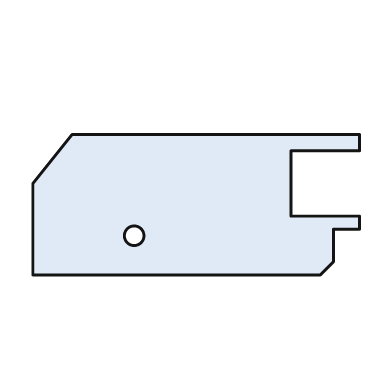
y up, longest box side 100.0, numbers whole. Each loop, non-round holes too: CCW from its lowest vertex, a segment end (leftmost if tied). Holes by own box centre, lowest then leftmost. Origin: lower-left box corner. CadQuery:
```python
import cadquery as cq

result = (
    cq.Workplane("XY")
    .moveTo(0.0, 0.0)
    .lineTo(88.0, 0.0)
    .lineTo(92.0, 4.0)
    .lineTo(92.0, 14.0)
    .lineTo(100.0, 14.0)
    .lineTo(100.0, 18.0)
    .lineTo(79.0, 18.0)
    .lineTo(79.0, 38.0)
    .lineTo(100.0, 38.0)
    .lineTo(100.0, 43.0)
    .lineTo(12.0, 43.0)
    .lineTo(0.0, 28.0)
    .close()
    .moveTo(31.0, 12.0)
    .circle(3.0)
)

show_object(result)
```